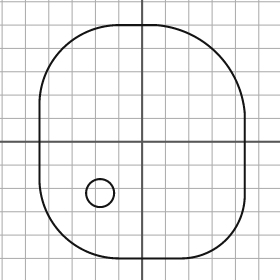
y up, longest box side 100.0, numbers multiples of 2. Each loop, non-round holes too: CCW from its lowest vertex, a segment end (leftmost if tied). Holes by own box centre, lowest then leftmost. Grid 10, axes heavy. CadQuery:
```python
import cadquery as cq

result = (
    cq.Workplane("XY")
    .moveTo(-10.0, -50.0)
    .lineTo(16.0, -50.0)
    .threePointArc((36.0, -42.0), (44.0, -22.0))
    .lineTo(44.0, 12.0)
    .threePointArc((32.0, 38.0), (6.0, 50.0))
    .lineTo(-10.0, 50.0)
    .threePointArc((-34.0, 40.0), (-44.0, 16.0))
    .lineTo(-44.0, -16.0)
    .threePointArc((-34.0, -40.0), (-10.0, -50.0))
    .close()
    .moveTo(-18.0, -22.0)
    .circle(6.0)
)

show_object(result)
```